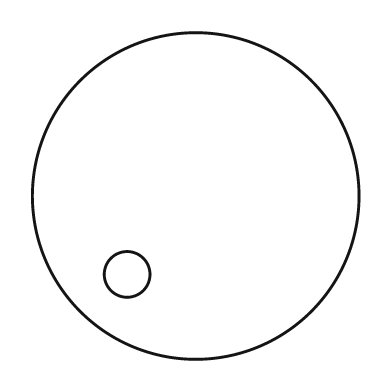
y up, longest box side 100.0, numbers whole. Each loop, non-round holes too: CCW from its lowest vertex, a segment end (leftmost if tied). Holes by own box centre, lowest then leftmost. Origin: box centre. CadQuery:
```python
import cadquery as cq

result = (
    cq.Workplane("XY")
    .moveTo(0.0, 0.0)
    .circle(50.0)
    .moveTo(-21.0, -24.0)
    .circle(7.0)
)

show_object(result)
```